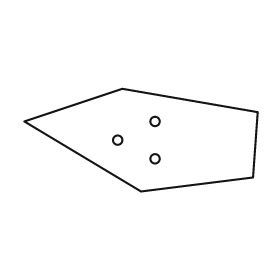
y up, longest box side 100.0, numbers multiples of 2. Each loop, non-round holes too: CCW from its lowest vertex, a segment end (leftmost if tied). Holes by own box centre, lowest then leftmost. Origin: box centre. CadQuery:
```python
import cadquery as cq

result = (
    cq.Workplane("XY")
    .moveTo(0.0, -22.0)
    .lineTo(48.0, -16.0)
    .lineTo(50.0, 12.0)
    .lineTo(-8.0, 22.0)
    .lineTo(-50.0, 8.0)
    .close()
    .moveTo(6.0, -8.0)
    .circle(2.0)
    .moveTo(-10.0, 0.0)
    .circle(2.0)
    .moveTo(6.0, 8.0)
    .circle(2.0)
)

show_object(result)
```